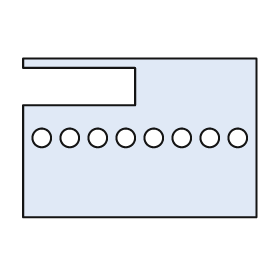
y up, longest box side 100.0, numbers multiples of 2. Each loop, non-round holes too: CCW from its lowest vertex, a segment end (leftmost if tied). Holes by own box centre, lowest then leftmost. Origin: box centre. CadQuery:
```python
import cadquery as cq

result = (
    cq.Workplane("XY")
    .moveTo(-50.0, -34.0)
    .lineTo(50.0, -34.0)
    .lineTo(50.0, 34.0)
    .lineTo(-50.0, 34.0)
    .lineTo(-50.0, 30.0)
    .lineTo(-2.0, 30.0)
    .lineTo(-2.0, 14.0)
    .lineTo(-50.0, 14.0)
    .close()
    .moveTo(-42.0, 0.0)
    .circle(4.0)
    .moveTo(-30.0, 0.0)
    .circle(4.0)
    .moveTo(-18.0, 0.0)
    .circle(4.0)
    .moveTo(-6.0, 0.0)
    .circle(4.0)
    .moveTo(6.0, 0.0)
    .circle(4.0)
    .moveTo(18.0, 0.0)
    .circle(4.0)
    .moveTo(30.0, 0.0)
    .circle(4.0)
    .moveTo(42.0, 0.0)
    .circle(4.0)
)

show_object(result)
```